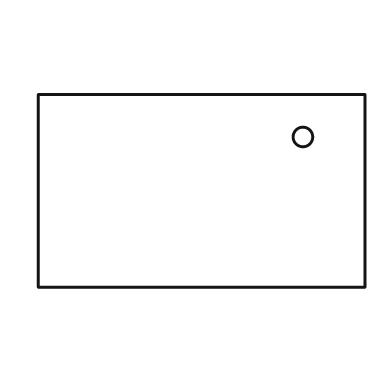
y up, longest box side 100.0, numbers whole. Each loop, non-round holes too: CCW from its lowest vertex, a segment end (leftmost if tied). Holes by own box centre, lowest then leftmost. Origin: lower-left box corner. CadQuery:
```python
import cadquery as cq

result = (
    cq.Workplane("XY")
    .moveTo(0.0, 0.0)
    .lineTo(100.0, 0.0)
    .lineTo(100.0, 59.0)
    .lineTo(0.0, 59.0)
    .close()
    .moveTo(81.0, 46.0)
    .circle(3.0)
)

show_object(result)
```